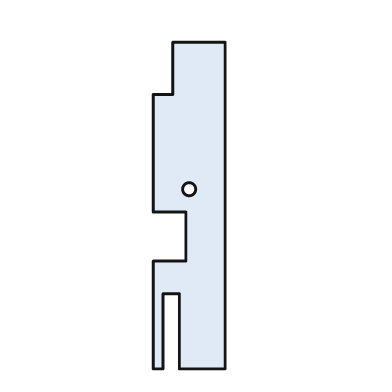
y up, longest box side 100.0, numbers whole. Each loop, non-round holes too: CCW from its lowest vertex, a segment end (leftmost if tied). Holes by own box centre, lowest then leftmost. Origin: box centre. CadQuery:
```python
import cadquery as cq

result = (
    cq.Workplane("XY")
    .moveTo(-11.0, -50.0)
    .lineTo(-8.0, -50.0)
    .lineTo(-8.0, -27.0)
    .lineTo(-3.0, -27.0)
    .lineTo(-3.0, -50.0)
    .lineTo(11.0, -50.0)
    .lineTo(11.0, 50.0)
    .lineTo(-5.0, 50.0)
    .lineTo(-5.0, 34.0)
    .lineTo(-11.0, 34.0)
    .lineTo(-11.0, -2.0)
    .lineTo(-1.0, -2.0)
    .lineTo(-1.0, -17.0)
    .lineTo(-11.0, -17.0)
    .close()
    .moveTo(0.0, 5.0)
    .circle(2.0)
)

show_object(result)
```